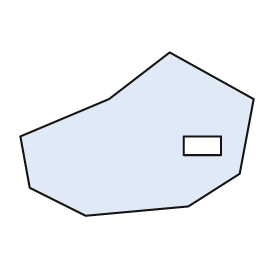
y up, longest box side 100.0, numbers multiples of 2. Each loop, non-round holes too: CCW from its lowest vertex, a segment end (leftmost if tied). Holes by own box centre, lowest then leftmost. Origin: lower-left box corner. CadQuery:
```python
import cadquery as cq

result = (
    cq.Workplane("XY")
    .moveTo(28.0, 0.0)
    .lineTo(72.0, 4.0)
    .lineTo(94.0, 18.0)
    .lineTo(100.0, 50.0)
    .lineTo(64.0, 70.0)
    .lineTo(38.0, 50.0)
    .lineTo(0.0, 34.0)
    .lineTo(4.0, 12.0)
    .close()
    .moveTo(70.0, 26.0)
    .lineTo(86.0, 26.0)
    .lineTo(86.0, 34.0)
    .lineTo(70.0, 34.0)
    .close()
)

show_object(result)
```